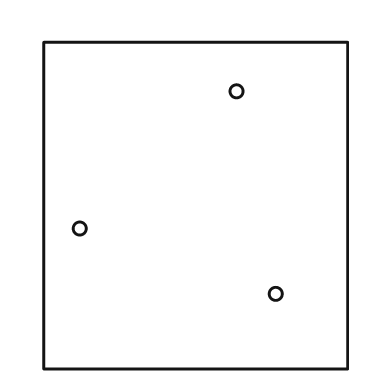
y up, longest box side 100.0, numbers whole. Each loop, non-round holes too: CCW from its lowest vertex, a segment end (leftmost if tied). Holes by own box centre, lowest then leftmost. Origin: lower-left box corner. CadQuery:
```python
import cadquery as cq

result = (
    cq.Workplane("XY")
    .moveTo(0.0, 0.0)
    .lineTo(93.0, 0.0)
    .lineTo(93.0, 100.0)
    .lineTo(0.0, 100.0)
    .close()
    .moveTo(71.0, 23.0)
    .circle(2.0)
    .moveTo(11.0, 43.0)
    .circle(2.0)
    .moveTo(59.0, 85.0)
    .circle(2.0)
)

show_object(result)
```